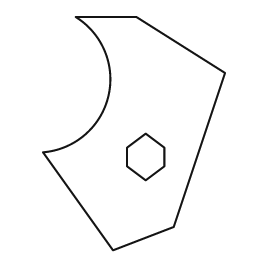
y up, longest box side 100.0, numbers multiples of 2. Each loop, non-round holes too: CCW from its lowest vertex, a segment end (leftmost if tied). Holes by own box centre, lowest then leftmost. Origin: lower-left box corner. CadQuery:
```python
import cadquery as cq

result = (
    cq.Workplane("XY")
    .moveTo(30.0, 0.0)
    .lineTo(56.0, 10.0)
    .lineTo(78.0, 76.0)
    .lineTo(40.0, 100.0)
    .lineTo(14.0, 100.0)
    .threePointArc((28.0, 66.0), (0.0, 42.0))
    .close()
    .moveTo(44.0, 30.0)
    .lineTo(52.0, 36.0)
    .lineTo(52.0, 44.0)
    .lineTo(44.0, 50.0)
    .lineTo(36.0, 44.0)
    .lineTo(36.0, 36.0)
    .close()
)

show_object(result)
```